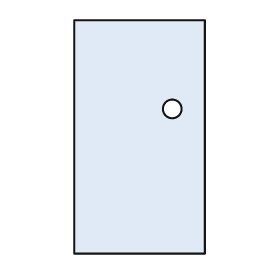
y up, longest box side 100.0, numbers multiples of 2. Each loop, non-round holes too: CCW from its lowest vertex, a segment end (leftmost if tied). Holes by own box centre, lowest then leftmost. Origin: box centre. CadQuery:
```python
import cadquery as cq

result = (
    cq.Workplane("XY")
    .moveTo(-28.0, -50.0)
    .lineTo(28.0, -50.0)
    .lineTo(28.0, 50.0)
    .lineTo(-28.0, 50.0)
    .close()
    .moveTo(14.0, 12.0)
    .circle(4.0)
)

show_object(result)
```